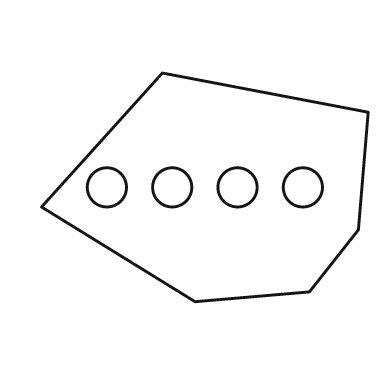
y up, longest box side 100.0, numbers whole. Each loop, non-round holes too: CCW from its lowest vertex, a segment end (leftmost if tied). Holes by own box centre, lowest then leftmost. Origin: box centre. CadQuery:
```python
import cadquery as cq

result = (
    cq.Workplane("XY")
    .moveTo(-3.0, -35.0)
    .lineTo(32.0, -32.0)
    .lineTo(47.0, -13.0)
    .lineTo(50.0, 23.0)
    .lineTo(-13.0, 35.0)
    .lineTo(-50.0, -6.0)
    .close()
    .moveTo(-30.0, 0.0)
    .circle(6.0)
    .moveTo(-10.0, 0.0)
    .circle(6.0)
    .moveTo(10.0, 0.0)
    .circle(6.0)
    .moveTo(30.0, 0.0)
    .circle(6.0)
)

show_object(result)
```